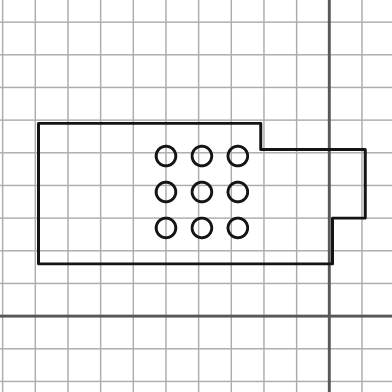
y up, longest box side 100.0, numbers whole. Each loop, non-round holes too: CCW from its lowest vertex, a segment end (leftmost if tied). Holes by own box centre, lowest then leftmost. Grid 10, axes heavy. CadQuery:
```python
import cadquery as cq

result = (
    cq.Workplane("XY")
    .moveTo(-89.0, 16.0)
    .lineTo(1.0, 16.0)
    .lineTo(1.0, 30.0)
    .lineTo(11.0, 30.0)
    .lineTo(11.0, 51.0)
    .lineTo(-21.0, 51.0)
    .lineTo(-21.0, 59.0)
    .lineTo(-89.0, 59.0)
    .close()
    .moveTo(-50.0, 27.0)
    .circle(3.0)
    .moveTo(-39.0, 27.0)
    .circle(3.0)
    .moveTo(-28.0, 27.0)
    .circle(3.0)
    .moveTo(-50.0, 38.0)
    .circle(3.0)
    .moveTo(-39.0, 38.0)
    .circle(3.0)
    .moveTo(-28.0, 38.0)
    .circle(3.0)
    .moveTo(-50.0, 49.0)
    .circle(3.0)
    .moveTo(-39.0, 49.0)
    .circle(3.0)
    .moveTo(-28.0, 49.0)
    .circle(3.0)
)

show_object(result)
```